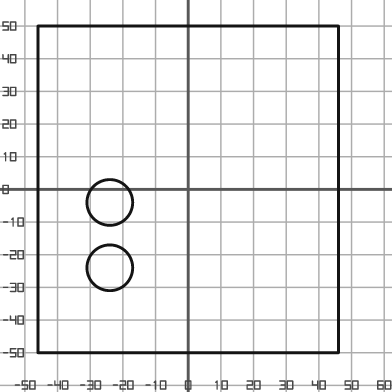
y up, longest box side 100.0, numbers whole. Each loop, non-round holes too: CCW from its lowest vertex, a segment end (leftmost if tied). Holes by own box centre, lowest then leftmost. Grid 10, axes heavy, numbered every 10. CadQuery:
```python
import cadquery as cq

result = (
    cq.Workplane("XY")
    .moveTo(-46.0, -50.0)
    .lineTo(46.0, -50.0)
    .lineTo(46.0, 50.0)
    .lineTo(-46.0, 50.0)
    .close()
    .moveTo(-24.0, -24.0)
    .circle(7.0)
    .moveTo(-24.0, -4.0)
    .circle(7.0)
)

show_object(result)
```